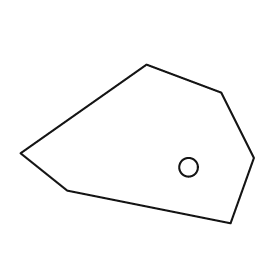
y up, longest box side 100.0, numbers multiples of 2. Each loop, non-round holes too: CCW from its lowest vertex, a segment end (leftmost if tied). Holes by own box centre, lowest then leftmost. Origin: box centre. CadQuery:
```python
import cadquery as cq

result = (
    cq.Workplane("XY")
    .moveTo(40.0, -34.0)
    .lineTo(50.0, -6.0)
    .lineTo(36.0, 22.0)
    .lineTo(4.0, 34.0)
    .lineTo(-50.0, -4.0)
    .lineTo(-30.0, -20.0)
    .close()
    .moveTo(22.0, -10.0)
    .circle(4.0)
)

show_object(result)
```